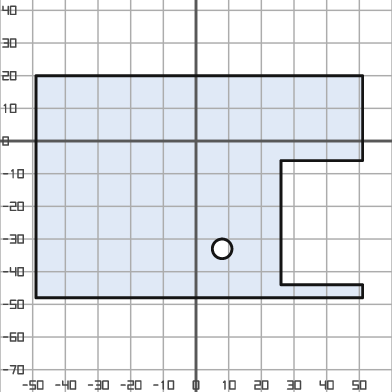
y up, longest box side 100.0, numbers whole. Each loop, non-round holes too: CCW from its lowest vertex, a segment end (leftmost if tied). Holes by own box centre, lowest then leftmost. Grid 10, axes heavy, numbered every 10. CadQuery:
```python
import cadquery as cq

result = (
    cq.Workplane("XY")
    .moveTo(-49.0, -48.0)
    .lineTo(51.0, -48.0)
    .lineTo(51.0, -44.0)
    .lineTo(26.0, -44.0)
    .lineTo(26.0, -6.0)
    .lineTo(51.0, -6.0)
    .lineTo(51.0, 20.0)
    .lineTo(-49.0, 20.0)
    .close()
    .moveTo(8.0, -33.0)
    .circle(3.0)
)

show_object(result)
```